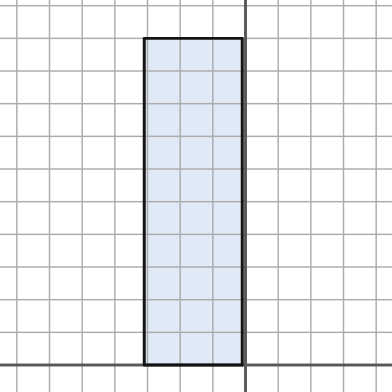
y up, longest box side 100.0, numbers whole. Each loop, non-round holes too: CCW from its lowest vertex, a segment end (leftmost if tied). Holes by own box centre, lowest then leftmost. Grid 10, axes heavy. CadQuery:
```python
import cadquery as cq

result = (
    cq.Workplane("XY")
    .moveTo(-31.0, 0.0)
    .lineTo(-1.0, 0.0)
    .lineTo(-1.0, 100.0)
    .lineTo(-31.0, 100.0)
    .close()
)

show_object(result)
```